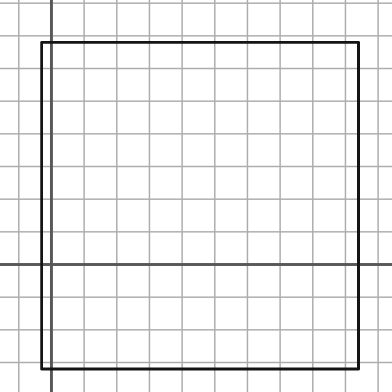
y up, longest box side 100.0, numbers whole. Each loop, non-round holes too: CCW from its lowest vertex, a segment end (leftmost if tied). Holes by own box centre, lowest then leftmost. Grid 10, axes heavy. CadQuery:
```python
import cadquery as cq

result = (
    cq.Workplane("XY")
    .moveTo(-3.0, -32.0)
    .lineTo(94.0, -32.0)
    .lineTo(94.0, 68.0)
    .lineTo(-3.0, 68.0)
    .close()
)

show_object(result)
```